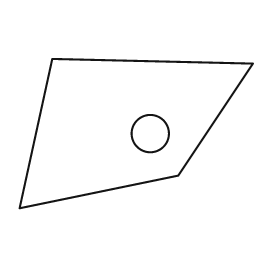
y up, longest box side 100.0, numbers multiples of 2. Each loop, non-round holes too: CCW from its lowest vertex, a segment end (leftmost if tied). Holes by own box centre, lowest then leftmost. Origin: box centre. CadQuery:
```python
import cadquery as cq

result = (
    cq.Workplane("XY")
    .moveTo(-50.0, -32.0)
    .lineTo(18.0, -18.0)
    .lineTo(50.0, 30.0)
    .lineTo(-36.0, 32.0)
    .close()
    .moveTo(6.0, 0.0)
    .circle(8.0)
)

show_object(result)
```